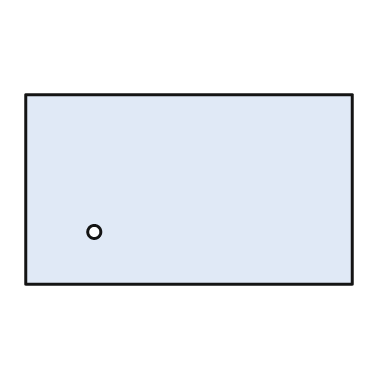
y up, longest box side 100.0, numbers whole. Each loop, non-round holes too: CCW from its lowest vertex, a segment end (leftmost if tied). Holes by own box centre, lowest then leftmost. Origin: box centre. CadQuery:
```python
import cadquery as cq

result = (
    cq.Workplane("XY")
    .moveTo(-50.0, -29.0)
    .lineTo(50.0, -29.0)
    .lineTo(50.0, 29.0)
    .lineTo(-50.0, 29.0)
    .close()
    .moveTo(-29.0, -13.0)
    .circle(2.0)
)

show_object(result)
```